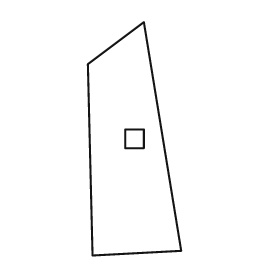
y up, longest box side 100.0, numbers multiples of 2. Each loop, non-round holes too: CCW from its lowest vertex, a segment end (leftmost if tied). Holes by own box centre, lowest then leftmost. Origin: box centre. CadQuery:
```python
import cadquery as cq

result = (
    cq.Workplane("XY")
    .moveTo(-18.0, -50.0)
    .lineTo(20.0, -48.0)
    .lineTo(4.0, 50.0)
    .lineTo(-20.0, 32.0)
    .close()
    .moveTo(-4.0, -4.0)
    .lineTo(4.0, -4.0)
    .lineTo(4.0, 4.0)
    .lineTo(-4.0, 4.0)
    .close()
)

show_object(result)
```